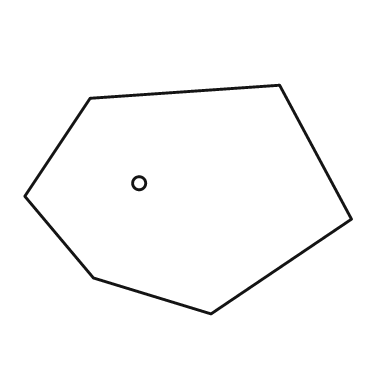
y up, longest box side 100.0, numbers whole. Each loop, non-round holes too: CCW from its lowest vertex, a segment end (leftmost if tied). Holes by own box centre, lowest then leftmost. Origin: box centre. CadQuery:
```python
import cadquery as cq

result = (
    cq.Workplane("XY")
    .moveTo(7.0, -35.0)
    .lineTo(50.0, -6.0)
    .lineTo(28.0, 35.0)
    .lineTo(-30.0, 31.0)
    .lineTo(-50.0, 1.0)
    .lineTo(-29.0, -24.0)
    .close()
    .moveTo(-15.0, 5.0)
    .circle(2.0)
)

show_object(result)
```